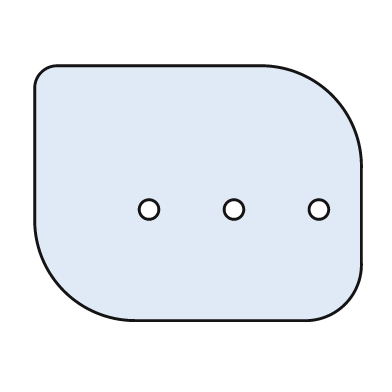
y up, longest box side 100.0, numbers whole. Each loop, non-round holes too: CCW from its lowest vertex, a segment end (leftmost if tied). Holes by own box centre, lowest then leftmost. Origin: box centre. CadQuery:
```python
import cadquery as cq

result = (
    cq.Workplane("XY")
    .moveTo(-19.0, -39.0)
    .lineTo(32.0, -39.0)
    .threePointArc((45.0, -34.0), (50.0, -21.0))
    .lineTo(50.0, 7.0)
    .threePointArc((41.0, 30.0), (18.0, 39.0))
    .lineTo(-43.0, 39.0)
    .threePointArc((-48.0, 37.0), (-50.0, 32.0))
    .lineTo(-50.0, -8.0)
    .threePointArc((-41.0, -30.0), (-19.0, -39.0))
    .close()
    .moveTo(-15.0, -5.0)
    .circle(3.0)
    .moveTo(11.0, -5.0)
    .circle(3.0)
    .moveTo(37.0, -5.0)
    .circle(3.0)
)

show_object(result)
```